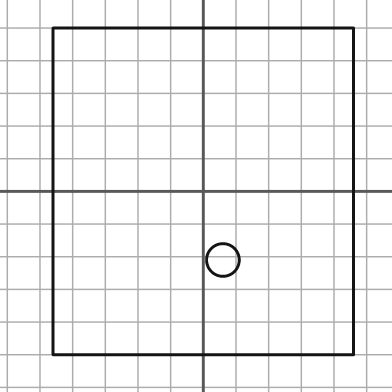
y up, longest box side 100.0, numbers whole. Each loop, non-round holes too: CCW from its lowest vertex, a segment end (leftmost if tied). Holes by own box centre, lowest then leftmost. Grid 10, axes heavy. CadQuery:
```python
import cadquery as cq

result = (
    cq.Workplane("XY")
    .moveTo(-46.0, -50.0)
    .lineTo(46.0, -50.0)
    .lineTo(46.0, 50.0)
    .lineTo(-46.0, 50.0)
    .close()
    .moveTo(6.0, -21.0)
    .circle(5.0)
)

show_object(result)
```